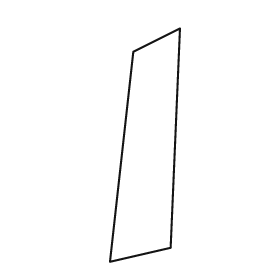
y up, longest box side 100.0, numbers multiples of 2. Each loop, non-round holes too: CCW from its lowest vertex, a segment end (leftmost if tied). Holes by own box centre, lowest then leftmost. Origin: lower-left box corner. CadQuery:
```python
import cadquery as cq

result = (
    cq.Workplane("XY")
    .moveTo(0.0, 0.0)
    .lineTo(26.0, 6.0)
    .lineTo(30.0, 100.0)
    .lineTo(10.0, 90.0)
    .close()
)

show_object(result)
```